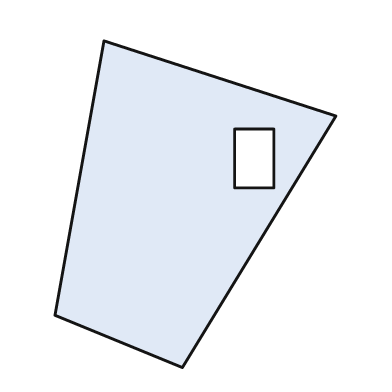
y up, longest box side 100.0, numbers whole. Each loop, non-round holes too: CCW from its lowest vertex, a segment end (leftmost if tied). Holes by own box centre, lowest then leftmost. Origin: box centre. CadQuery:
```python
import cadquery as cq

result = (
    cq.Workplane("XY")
    .moveTo(-4.0, -50.0)
    .lineTo(43.0, 27.0)
    .lineTo(-28.0, 50.0)
    .lineTo(-43.0, -34.0)
    .close()
    .moveTo(12.0, 5.0)
    .lineTo(24.0, 5.0)
    .lineTo(24.0, 23.0)
    .lineTo(12.0, 23.0)
    .close()
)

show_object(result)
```